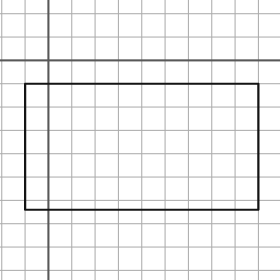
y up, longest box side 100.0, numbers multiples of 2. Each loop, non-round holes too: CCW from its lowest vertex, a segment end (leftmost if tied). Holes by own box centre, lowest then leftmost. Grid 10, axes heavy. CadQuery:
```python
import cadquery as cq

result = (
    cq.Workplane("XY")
    .moveTo(-10.0, -64.0)
    .lineTo(90.0, -64.0)
    .lineTo(90.0, -10.0)
    .lineTo(-10.0, -10.0)
    .close()
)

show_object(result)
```